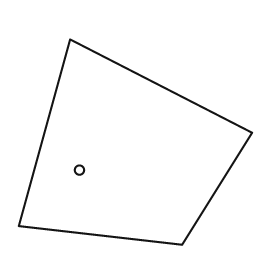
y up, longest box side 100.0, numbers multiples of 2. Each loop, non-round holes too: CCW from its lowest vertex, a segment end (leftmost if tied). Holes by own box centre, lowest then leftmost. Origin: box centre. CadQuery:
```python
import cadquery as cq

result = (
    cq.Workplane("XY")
    .moveTo(20.0, -44.0)
    .lineTo(50.0, 4.0)
    .lineTo(-28.0, 44.0)
    .lineTo(-50.0, -36.0)
    .close()
    .moveTo(-24.0, -12.0)
    .circle(2.0)
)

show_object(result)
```